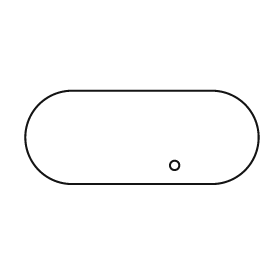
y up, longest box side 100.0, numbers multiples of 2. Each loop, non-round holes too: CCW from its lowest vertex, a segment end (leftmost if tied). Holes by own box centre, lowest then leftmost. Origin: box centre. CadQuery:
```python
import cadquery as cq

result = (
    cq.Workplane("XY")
    .moveTo(-30.0, -20.0)
    .lineTo(30.0, -20.0)
    .threePointArc((50.0, 0.0), (30.0, 20.0))
    .lineTo(-30.0, 20.0)
    .threePointArc((-50.0, 0.0), (-30.0, -20.0))
    .close()
    .moveTo(14.0, -12.0)
    .circle(2.0)
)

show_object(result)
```